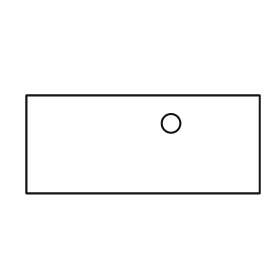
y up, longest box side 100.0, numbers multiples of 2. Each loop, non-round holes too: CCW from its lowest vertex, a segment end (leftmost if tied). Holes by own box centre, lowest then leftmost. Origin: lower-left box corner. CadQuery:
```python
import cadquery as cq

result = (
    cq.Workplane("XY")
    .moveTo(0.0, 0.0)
    .lineTo(100.0, 0.0)
    .lineTo(100.0, 42.0)
    .lineTo(0.0, 42.0)
    .close()
    .moveTo(62.0, 30.0)
    .circle(4.0)
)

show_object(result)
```